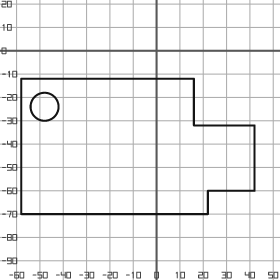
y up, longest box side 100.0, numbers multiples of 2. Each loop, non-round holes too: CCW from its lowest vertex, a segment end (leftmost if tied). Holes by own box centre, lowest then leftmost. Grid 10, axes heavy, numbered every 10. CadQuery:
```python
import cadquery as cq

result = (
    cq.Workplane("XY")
    .moveTo(-58.0, -70.0)
    .lineTo(22.0, -70.0)
    .lineTo(22.0, -60.0)
    .lineTo(42.0, -60.0)
    .lineTo(42.0, -32.0)
    .lineTo(16.0, -32.0)
    .lineTo(16.0, -12.0)
    .lineTo(-58.0, -12.0)
    .close()
    .moveTo(-48.0, -24.0)
    .circle(6.0)
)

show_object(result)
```